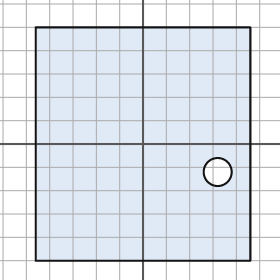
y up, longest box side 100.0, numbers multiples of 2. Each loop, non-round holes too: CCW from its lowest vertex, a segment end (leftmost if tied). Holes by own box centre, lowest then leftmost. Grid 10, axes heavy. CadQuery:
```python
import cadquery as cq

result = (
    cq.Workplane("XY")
    .moveTo(-46.0, -50.0)
    .lineTo(46.0, -50.0)
    .lineTo(46.0, 50.0)
    .lineTo(-46.0, 50.0)
    .close()
    .moveTo(32.0, -12.0)
    .circle(6.0)
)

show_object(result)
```